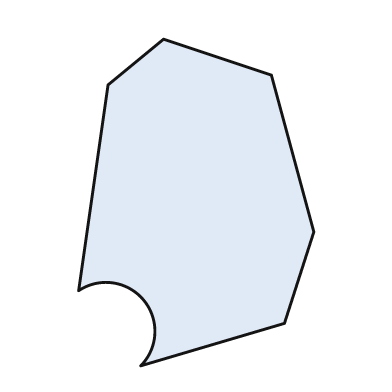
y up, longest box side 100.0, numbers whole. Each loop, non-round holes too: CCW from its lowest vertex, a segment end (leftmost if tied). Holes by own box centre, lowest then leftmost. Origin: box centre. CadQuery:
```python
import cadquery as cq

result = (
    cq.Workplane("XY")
    .moveTo(-17.0, -50.0)
    .lineTo(27.0, -37.0)
    .lineTo(36.0, -9.0)
    .lineTo(23.0, 39.0)
    .lineTo(-10.0, 50.0)
    .lineTo(-27.0, 36.0)
    .lineTo(-36.0, -27.0)
    .threePointArc((-16.0, -30.0), (-17.0, -50.0))
    .close()
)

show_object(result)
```